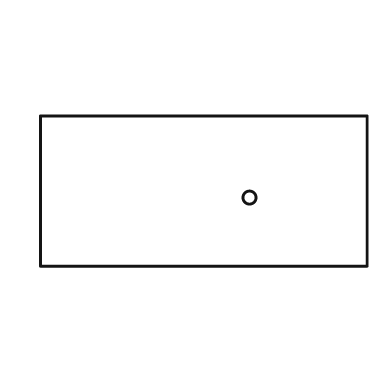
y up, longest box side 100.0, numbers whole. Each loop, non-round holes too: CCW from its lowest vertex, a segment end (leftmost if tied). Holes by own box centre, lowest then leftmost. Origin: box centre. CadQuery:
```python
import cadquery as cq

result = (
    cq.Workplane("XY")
    .moveTo(-50.0, -23.0)
    .lineTo(50.0, -23.0)
    .lineTo(50.0, 23.0)
    .lineTo(-50.0, 23.0)
    .close()
    .moveTo(14.0, -2.0)
    .circle(2.0)
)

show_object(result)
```